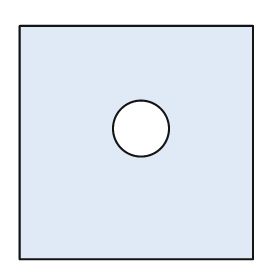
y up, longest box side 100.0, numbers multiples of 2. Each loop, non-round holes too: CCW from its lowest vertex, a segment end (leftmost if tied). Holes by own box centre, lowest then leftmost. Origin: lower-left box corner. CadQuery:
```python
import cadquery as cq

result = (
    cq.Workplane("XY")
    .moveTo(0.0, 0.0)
    .lineTo(100.0, 0.0)
    .lineTo(100.0, 100.0)
    .lineTo(0.0, 100.0)
    .close()
    .moveTo(52.0, 56.0)
    .circle(12.0)
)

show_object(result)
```